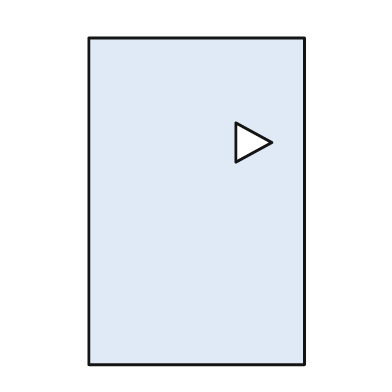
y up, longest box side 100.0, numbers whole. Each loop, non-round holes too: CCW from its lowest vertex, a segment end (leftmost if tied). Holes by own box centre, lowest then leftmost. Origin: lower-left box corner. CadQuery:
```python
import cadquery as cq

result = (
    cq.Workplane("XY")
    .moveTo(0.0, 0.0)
    .lineTo(66.0, 0.0)
    .lineTo(66.0, 100.0)
    .lineTo(0.0, 100.0)
    .close()
    .moveTo(45.0, 62.0)
    .lineTo(56.0, 68.0)
    .lineTo(45.0, 74.0)
    .close()
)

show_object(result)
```